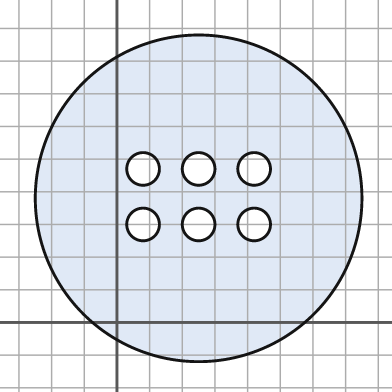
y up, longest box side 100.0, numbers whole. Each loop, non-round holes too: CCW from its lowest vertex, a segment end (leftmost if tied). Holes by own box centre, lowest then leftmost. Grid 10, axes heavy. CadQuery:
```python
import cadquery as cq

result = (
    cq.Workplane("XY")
    .moveTo(25.0, 38.0)
    .circle(50.0)
    .moveTo(8.0, 30.0)
    .circle(5.0)
    .moveTo(25.0, 30.0)
    .circle(5.0)
    .moveTo(42.0, 30.0)
    .circle(5.0)
    .moveTo(8.0, 47.0)
    .circle(5.0)
    .moveTo(25.0, 47.0)
    .circle(5.0)
    .moveTo(42.0, 47.0)
    .circle(5.0)
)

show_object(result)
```